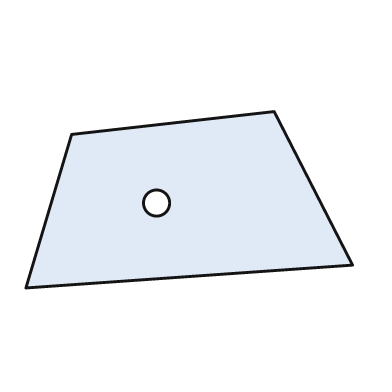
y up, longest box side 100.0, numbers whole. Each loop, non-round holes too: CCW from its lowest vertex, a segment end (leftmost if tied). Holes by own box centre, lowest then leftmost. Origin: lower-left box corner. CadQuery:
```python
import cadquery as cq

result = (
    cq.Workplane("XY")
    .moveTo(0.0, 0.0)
    .lineTo(100.0, 7.0)
    .lineTo(76.0, 54.0)
    .lineTo(14.0, 47.0)
    .close()
    .moveTo(40.0, 26.0)
    .circle(4.0)
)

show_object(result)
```